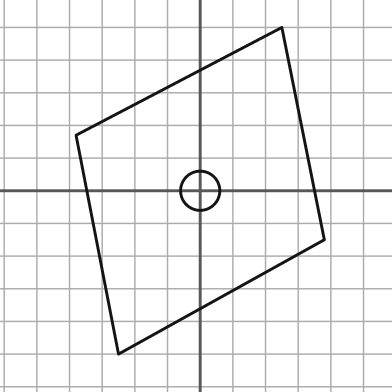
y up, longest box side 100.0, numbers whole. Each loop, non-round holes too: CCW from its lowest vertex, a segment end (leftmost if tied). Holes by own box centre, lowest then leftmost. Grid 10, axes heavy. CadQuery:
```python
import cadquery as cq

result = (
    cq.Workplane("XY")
    .moveTo(-25.0, -50.0)
    .lineTo(38.0, -15.0)
    .lineTo(25.0, 50.0)
    .lineTo(-38.0, 17.0)
    .close()
    .moveTo(0.0, 0.0)
    .circle(6.0)
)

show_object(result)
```